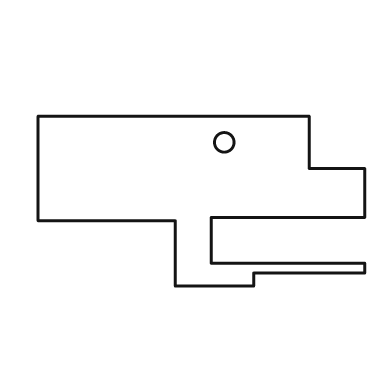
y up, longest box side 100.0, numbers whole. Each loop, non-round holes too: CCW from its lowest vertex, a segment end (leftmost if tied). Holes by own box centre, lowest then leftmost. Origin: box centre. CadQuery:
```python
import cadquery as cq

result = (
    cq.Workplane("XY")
    .moveTo(-8.0, -26.0)
    .lineTo(16.0, -26.0)
    .lineTo(16.0, -22.0)
    .lineTo(50.0, -22.0)
    .lineTo(50.0, -19.0)
    .lineTo(3.0, -19.0)
    .lineTo(3.0, -5.0)
    .lineTo(50.0, -5.0)
    .lineTo(50.0, 10.0)
    .lineTo(33.0, 10.0)
    .lineTo(33.0, 26.0)
    .lineTo(-50.0, 26.0)
    .lineTo(-50.0, -6.0)
    .lineTo(-8.0, -6.0)
    .close()
    .moveTo(7.0, 18.0)
    .circle(3.0)
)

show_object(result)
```